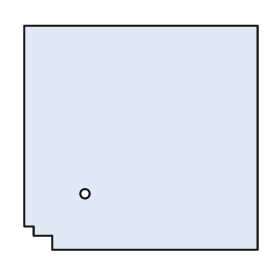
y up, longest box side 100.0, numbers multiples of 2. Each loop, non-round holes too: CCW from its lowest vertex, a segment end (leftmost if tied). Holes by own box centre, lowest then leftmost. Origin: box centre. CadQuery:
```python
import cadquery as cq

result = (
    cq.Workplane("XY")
    .moveTo(-38.0, -48.0)
    .lineTo(50.0, -48.0)
    .lineTo(50.0, 48.0)
    .lineTo(-50.0, 48.0)
    .lineTo(-50.0, -38.0)
    .lineTo(-46.0, -38.0)
    .lineTo(-46.0, -42.0)
    .lineTo(-38.0, -42.0)
    .close()
    .moveTo(-24.0, -24.0)
    .circle(2.0)
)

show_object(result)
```